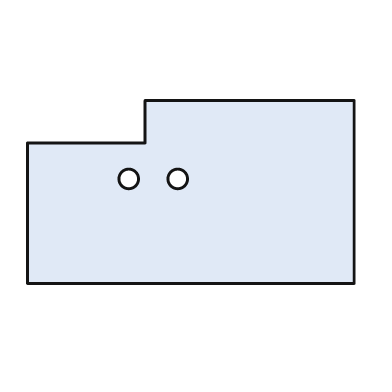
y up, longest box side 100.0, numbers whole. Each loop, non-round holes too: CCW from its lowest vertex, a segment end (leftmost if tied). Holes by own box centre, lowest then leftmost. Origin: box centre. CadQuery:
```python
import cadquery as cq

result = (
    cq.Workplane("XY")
    .moveTo(-50.0, -28.0)
    .lineTo(50.0, -28.0)
    .lineTo(50.0, 28.0)
    .lineTo(-14.0, 28.0)
    .lineTo(-14.0, 15.0)
    .lineTo(-50.0, 15.0)
    .close()
    .moveTo(-19.0, 4.0)
    .circle(3.0)
    .moveTo(-4.0, 4.0)
    .circle(3.0)
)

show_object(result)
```